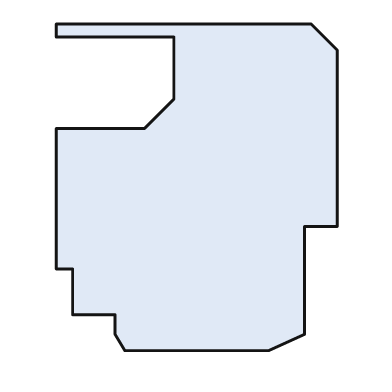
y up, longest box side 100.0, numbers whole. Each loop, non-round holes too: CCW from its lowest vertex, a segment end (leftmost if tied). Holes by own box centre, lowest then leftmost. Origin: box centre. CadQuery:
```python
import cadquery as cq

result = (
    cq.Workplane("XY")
    .moveTo(-22.0, -50.0)
    .lineTo(22.0, -50.0)
    .lineTo(33.0, -45.0)
    .lineTo(33.0, -12.0)
    .lineTo(43.0, -12.0)
    .lineTo(43.0, 42.0)
    .lineTo(35.0, 50.0)
    .lineTo(-43.0, 50.0)
    .lineTo(-43.0, 46.0)
    .lineTo(-7.0, 46.0)
    .lineTo(-7.0, 27.0)
    .lineTo(-16.0, 18.0)
    .lineTo(-43.0, 18.0)
    .lineTo(-43.0, -25.0)
    .lineTo(-38.0, -25.0)
    .lineTo(-38.0, -39.0)
    .lineTo(-25.0, -39.0)
    .lineTo(-25.0, -45.0)
    .close()
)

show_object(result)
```